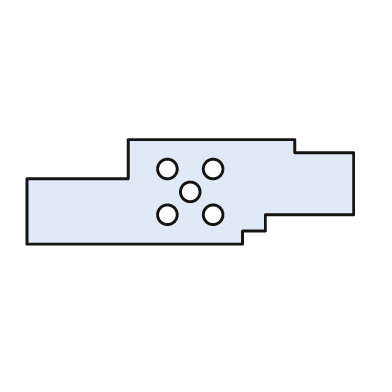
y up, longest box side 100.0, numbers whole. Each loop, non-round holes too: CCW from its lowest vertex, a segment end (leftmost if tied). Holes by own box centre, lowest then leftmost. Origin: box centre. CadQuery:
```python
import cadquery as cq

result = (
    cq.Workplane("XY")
    .moveTo(-50.0, -16.0)
    .lineTo(16.0, -16.0)
    .lineTo(16.0, -12.0)
    .lineTo(23.0, -12.0)
    .lineTo(23.0, -7.0)
    .lineTo(50.0, -7.0)
    .lineTo(50.0, 12.0)
    .lineTo(32.0, 12.0)
    .lineTo(32.0, 16.0)
    .lineTo(-19.0, 16.0)
    .lineTo(-19.0, 4.0)
    .lineTo(-50.0, 4.0)
    .close()
    .moveTo(-7.0, -7.0)
    .circle(3.0)
    .moveTo(7.0, -7.0)
    .circle(3.0)
    .moveTo(0.0, 0.0)
    .circle(3.0)
    .moveTo(-7.0, 7.0)
    .circle(3.0)
    .moveTo(7.0, 7.0)
    .circle(3.0)
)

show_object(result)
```